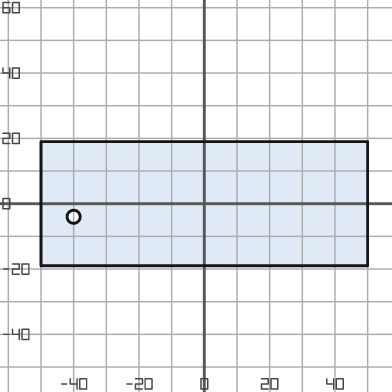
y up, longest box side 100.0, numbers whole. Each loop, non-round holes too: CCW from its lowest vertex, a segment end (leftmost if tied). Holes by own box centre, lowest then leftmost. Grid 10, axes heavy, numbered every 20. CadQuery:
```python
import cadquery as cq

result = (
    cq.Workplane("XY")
    .moveTo(-50.0, -19.0)
    .lineTo(50.0, -19.0)
    .lineTo(50.0, 19.0)
    .lineTo(-50.0, 19.0)
    .close()
    .moveTo(-40.0, -4.0)
    .circle(2.0)
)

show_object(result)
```